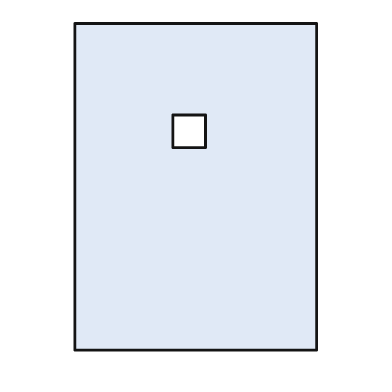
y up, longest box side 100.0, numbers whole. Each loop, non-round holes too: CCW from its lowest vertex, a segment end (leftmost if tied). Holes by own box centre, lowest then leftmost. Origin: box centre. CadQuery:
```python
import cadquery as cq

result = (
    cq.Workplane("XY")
    .moveTo(-37.0, -50.0)
    .lineTo(37.0, -50.0)
    .lineTo(37.0, 50.0)
    .lineTo(-37.0, 50.0)
    .close()
    .moveTo(-7.0, 12.0)
    .lineTo(3.0, 12.0)
    .lineTo(3.0, 22.0)
    .lineTo(-7.0, 22.0)
    .close()
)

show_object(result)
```